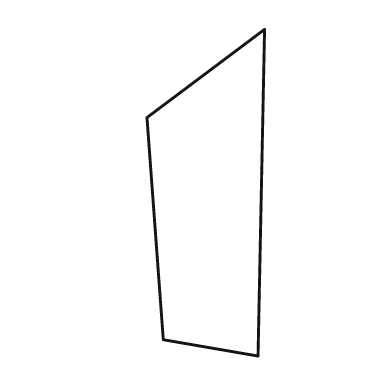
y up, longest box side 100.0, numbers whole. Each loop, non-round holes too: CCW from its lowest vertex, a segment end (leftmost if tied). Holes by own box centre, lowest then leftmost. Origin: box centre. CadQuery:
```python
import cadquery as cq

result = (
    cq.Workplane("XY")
    .moveTo(16.0, -50.0)
    .lineTo(18.0, 50.0)
    .lineTo(-18.0, 23.0)
    .lineTo(-13.0, -45.0)
    .close()
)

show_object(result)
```